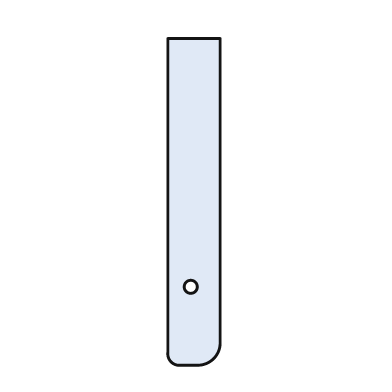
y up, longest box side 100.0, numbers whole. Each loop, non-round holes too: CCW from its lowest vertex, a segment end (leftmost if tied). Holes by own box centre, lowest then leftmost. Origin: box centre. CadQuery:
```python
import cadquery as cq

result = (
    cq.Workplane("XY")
    .moveTo(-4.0, -50.0)
    .lineTo(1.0, -50.0)
    .threePointArc((6.0, -48.0), (8.0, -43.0))
    .lineTo(8.0, 50.0)
    .lineTo(-8.0, 50.0)
    .lineTo(-8.0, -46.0)
    .threePointArc((-7.0, -49.0), (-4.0, -50.0))
    .close()
    .moveTo(-1.0, -26.0)
    .circle(2.0)
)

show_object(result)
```